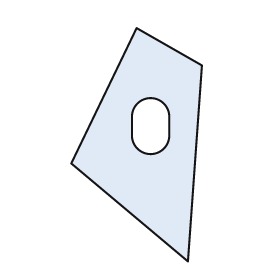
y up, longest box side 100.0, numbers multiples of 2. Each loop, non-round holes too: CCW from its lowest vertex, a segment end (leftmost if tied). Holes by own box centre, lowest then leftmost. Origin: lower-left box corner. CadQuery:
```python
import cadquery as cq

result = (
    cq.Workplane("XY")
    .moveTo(50.0, 0.0)
    .lineTo(56.0, 84.0)
    .lineTo(28.0, 100.0)
    .lineTo(0.0, 42.0)
    .close()
    .moveTo(26.0, 54.0)
    .threePointArc((34.0, 46.0), (42.0, 54.0))
    .lineTo(42.0, 62.0)
    .threePointArc((34.0, 70.0), (26.0, 62.0))
    .close()
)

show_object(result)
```